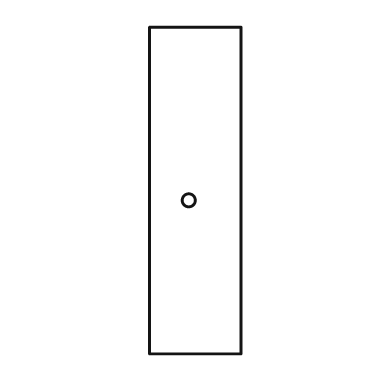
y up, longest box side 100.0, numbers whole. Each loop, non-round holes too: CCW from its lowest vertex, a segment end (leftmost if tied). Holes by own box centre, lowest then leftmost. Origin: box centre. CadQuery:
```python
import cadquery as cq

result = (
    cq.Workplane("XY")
    .moveTo(-14.0, -50.0)
    .lineTo(14.0, -50.0)
    .lineTo(14.0, 50.0)
    .lineTo(-14.0, 50.0)
    .close()
    .moveTo(-2.0, -3.0)
    .circle(2.0)
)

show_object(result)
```